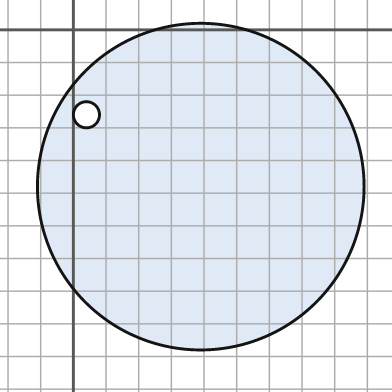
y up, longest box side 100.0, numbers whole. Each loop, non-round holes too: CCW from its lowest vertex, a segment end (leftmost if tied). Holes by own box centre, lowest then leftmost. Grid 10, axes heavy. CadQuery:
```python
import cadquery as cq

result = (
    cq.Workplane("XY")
    .moveTo(39.0, -48.0)
    .circle(50.0)
    .moveTo(4.0, -26.0)
    .circle(4.0)
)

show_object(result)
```